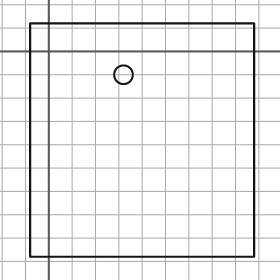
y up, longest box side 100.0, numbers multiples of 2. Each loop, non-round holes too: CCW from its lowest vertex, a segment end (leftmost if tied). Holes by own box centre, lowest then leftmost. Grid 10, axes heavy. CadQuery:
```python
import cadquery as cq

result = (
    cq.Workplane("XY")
    .moveTo(-8.0, -88.0)
    .lineTo(88.0, -88.0)
    .lineTo(88.0, 12.0)
    .lineTo(-8.0, 12.0)
    .close()
    .moveTo(32.0, -10.0)
    .circle(4.0)
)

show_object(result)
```